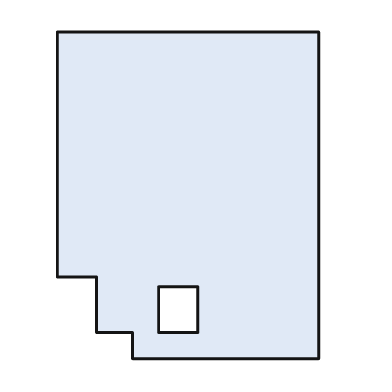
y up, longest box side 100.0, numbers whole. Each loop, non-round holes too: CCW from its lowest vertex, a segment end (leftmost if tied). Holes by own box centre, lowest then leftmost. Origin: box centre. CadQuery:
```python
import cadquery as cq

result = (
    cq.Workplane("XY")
    .moveTo(-17.0, -50.0)
    .lineTo(40.0, -50.0)
    .lineTo(40.0, 50.0)
    .lineTo(-40.0, 50.0)
    .lineTo(-40.0, -25.0)
    .lineTo(-28.0, -25.0)
    .lineTo(-28.0, -42.0)
    .lineTo(-17.0, -42.0)
    .close()
    .moveTo(-9.0, -42.0)
    .lineTo(3.0, -42.0)
    .lineTo(3.0, -28.0)
    .lineTo(-9.0, -28.0)
    .close()
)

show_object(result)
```